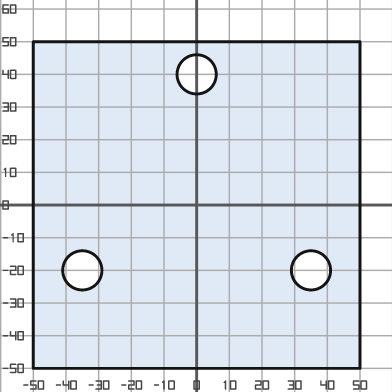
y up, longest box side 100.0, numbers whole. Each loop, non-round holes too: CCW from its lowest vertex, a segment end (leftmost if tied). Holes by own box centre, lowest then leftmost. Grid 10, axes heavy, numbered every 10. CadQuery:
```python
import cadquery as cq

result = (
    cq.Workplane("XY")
    .moveTo(-50.0, -50.0)
    .lineTo(50.0, -50.0)
    .lineTo(50.0, 50.0)
    .lineTo(-50.0, 50.0)
    .close()
    .moveTo(-35.0, -20.0)
    .circle(6.0)
    .moveTo(35.0, -20.0)
    .circle(6.0)
    .moveTo(0.0, 40.0)
    .circle(6.0)
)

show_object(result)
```